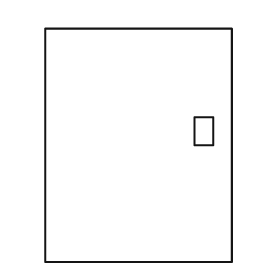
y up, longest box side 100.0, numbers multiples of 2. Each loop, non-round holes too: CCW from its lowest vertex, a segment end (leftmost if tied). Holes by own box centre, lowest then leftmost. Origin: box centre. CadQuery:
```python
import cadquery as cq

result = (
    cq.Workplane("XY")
    .moveTo(-40.0, -50.0)
    .lineTo(40.0, -50.0)
    .lineTo(40.0, 50.0)
    .lineTo(-40.0, 50.0)
    .close()
    .moveTo(24.0, 0.0)
    .lineTo(32.0, 0.0)
    .lineTo(32.0, 12.0)
    .lineTo(24.0, 12.0)
    .close()
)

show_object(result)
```